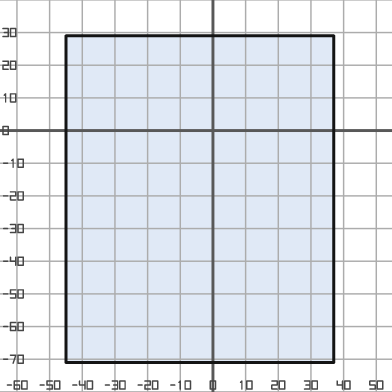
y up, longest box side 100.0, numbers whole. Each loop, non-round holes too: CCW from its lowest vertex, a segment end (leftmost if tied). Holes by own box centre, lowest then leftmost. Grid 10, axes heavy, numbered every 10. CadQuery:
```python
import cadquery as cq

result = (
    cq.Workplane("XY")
    .moveTo(-45.0, -71.0)
    .lineTo(37.0, -71.0)
    .lineTo(37.0, 29.0)
    .lineTo(-45.0, 29.0)
    .close()
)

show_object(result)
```